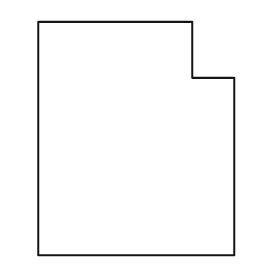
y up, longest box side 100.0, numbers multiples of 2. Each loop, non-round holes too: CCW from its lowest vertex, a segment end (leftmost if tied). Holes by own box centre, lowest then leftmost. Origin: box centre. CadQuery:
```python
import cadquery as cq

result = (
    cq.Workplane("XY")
    .moveTo(-42.0, -50.0)
    .lineTo(42.0, -50.0)
    .lineTo(42.0, 26.0)
    .lineTo(24.0, 26.0)
    .lineTo(24.0, 50.0)
    .lineTo(-42.0, 50.0)
    .close()
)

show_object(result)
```